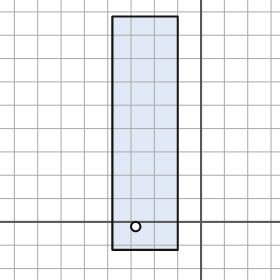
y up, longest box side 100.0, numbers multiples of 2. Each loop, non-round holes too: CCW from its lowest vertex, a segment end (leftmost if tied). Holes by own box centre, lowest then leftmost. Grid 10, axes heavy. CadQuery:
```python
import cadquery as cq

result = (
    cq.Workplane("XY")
    .moveTo(-38.0, -12.0)
    .lineTo(-10.0, -12.0)
    .lineTo(-10.0, 88.0)
    .lineTo(-38.0, 88.0)
    .close()
    .moveTo(-28.0, -2.0)
    .circle(2.0)
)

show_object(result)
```